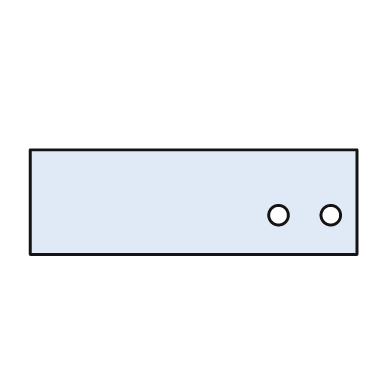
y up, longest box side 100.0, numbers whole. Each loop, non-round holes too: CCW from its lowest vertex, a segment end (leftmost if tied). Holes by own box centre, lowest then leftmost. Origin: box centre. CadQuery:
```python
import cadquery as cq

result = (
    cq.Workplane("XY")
    .moveTo(-50.0, -16.0)
    .lineTo(50.0, -16.0)
    .lineTo(50.0, 16.0)
    .lineTo(-50.0, 16.0)
    .close()
    .moveTo(26.0, -4.0)
    .circle(3.0)
    .moveTo(42.0, -4.0)
    .circle(3.0)
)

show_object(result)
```